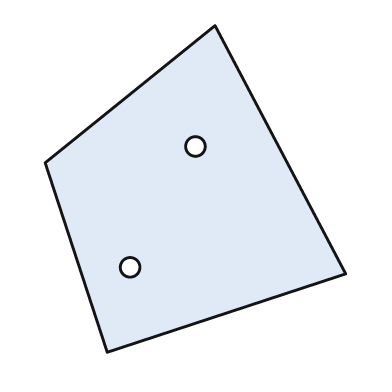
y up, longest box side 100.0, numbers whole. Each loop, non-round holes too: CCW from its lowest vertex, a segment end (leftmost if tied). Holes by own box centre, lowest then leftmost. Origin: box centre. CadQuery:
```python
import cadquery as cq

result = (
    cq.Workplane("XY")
    .moveTo(-27.0, -50.0)
    .lineTo(46.0, -26.0)
    .lineTo(6.0, 50.0)
    .lineTo(-46.0, 8.0)
    .close()
    .moveTo(-20.0, -24.0)
    .circle(3.0)
    .moveTo(0.0, 13.0)
    .circle(3.0)
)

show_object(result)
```